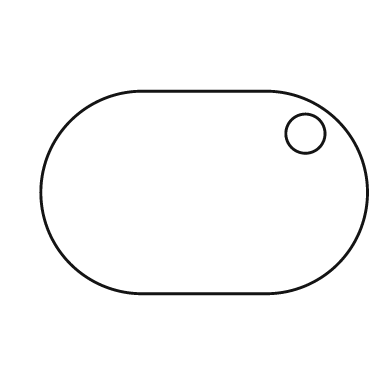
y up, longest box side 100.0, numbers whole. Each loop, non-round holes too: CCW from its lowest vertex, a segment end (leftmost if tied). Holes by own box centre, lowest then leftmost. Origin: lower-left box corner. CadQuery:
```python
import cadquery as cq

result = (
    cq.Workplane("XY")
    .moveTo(31.0, 0.0)
    .lineTo(69.0, 0.0)
    .threePointArc((100.0, 31.0), (69.0, 62.0))
    .lineTo(31.0, 62.0)
    .threePointArc((0.0, 31.0), (31.0, 0.0))
    .close()
    .moveTo(81.0, 49.0)
    .circle(6.0)
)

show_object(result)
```